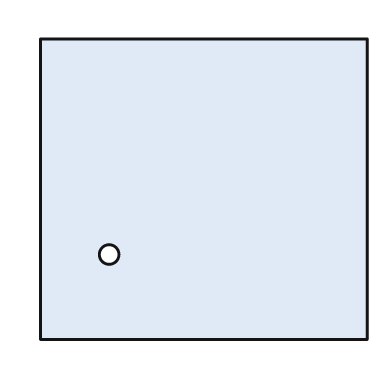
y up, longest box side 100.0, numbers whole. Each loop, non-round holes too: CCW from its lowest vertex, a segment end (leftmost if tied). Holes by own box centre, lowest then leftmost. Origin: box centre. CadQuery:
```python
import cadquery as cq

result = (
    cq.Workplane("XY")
    .moveTo(-50.0, -46.0)
    .lineTo(50.0, -46.0)
    .lineTo(50.0, 46.0)
    .lineTo(-50.0, 46.0)
    .close()
    .moveTo(-29.0, -20.0)
    .circle(3.0)
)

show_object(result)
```